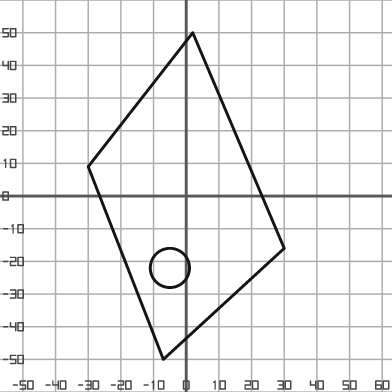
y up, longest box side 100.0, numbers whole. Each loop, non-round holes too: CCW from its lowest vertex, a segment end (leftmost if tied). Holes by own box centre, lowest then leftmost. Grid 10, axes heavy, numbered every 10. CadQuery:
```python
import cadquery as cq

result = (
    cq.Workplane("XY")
    .moveTo(-7.0, -50.0)
    .lineTo(30.0, -16.0)
    .lineTo(2.0, 50.0)
    .lineTo(-30.0, 9.0)
    .close()
    .moveTo(-5.0, -22.0)
    .circle(6.0)
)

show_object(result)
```